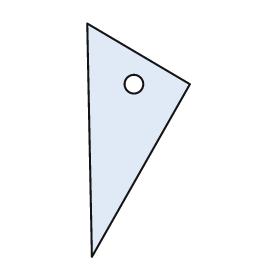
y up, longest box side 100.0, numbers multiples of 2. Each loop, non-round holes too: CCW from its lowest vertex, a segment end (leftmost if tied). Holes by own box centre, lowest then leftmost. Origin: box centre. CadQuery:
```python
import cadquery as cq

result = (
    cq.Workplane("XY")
    .moveTo(-20.0, -50.0)
    .lineTo(22.0, 24.0)
    .lineTo(-22.0, 50.0)
    .close()
    .moveTo(-2.0, 24.0)
    .circle(4.0)
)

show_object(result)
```